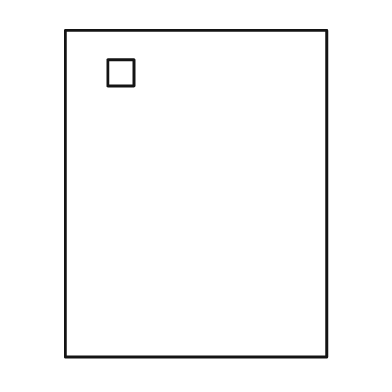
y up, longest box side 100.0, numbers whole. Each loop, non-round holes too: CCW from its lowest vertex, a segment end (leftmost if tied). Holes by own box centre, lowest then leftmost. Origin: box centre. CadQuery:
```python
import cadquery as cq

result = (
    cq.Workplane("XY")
    .moveTo(-40.0, -50.0)
    .lineTo(40.0, -50.0)
    .lineTo(40.0, 50.0)
    .lineTo(-40.0, 50.0)
    .close()
    .moveTo(-27.0, 33.0)
    .lineTo(-19.0, 33.0)
    .lineTo(-19.0, 41.0)
    .lineTo(-27.0, 41.0)
    .close()
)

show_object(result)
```